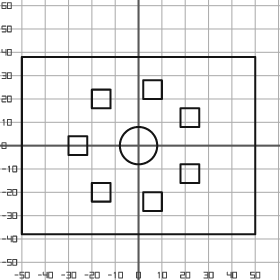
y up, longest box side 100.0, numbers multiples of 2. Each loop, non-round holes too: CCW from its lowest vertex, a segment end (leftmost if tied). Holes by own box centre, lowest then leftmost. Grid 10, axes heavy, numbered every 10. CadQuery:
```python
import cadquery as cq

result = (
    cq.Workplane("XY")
    .moveTo(-50.0, -38.0)
    .lineTo(50.0, -38.0)
    .lineTo(50.0, 38.0)
    .lineTo(-50.0, 38.0)
    .close()
    .moveTo(2.0, -28.0)
    .lineTo(10.0, -28.0)
    .lineTo(10.0, -20.0)
    .lineTo(2.0, -20.0)
    .close()
    .moveTo(-20.0, -24.0)
    .lineTo(-12.0, -24.0)
    .lineTo(-12.0, -16.0)
    .lineTo(-20.0, -16.0)
    .close()
    .moveTo(18.0, -16.0)
    .lineTo(26.0, -16.0)
    .lineTo(26.0, -8.0)
    .lineTo(18.0, -8.0)
    .close()
    .moveTo(-30.0, -4.0)
    .lineTo(-22.0, -4.0)
    .lineTo(-22.0, 4.0)
    .lineTo(-30.0, 4.0)
    .close()
    .moveTo(0.0, 0.0)
    .circle(8.0)
    .moveTo(18.0, 8.0)
    .lineTo(26.0, 8.0)
    .lineTo(26.0, 16.0)
    .lineTo(18.0, 16.0)
    .close()
    .moveTo(-20.0, 16.0)
    .lineTo(-12.0, 16.0)
    .lineTo(-12.0, 24.0)
    .lineTo(-20.0, 24.0)
    .close()
    .moveTo(2.0, 20.0)
    .lineTo(10.0, 20.0)
    .lineTo(10.0, 28.0)
    .lineTo(2.0, 28.0)
    .close()
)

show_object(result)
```